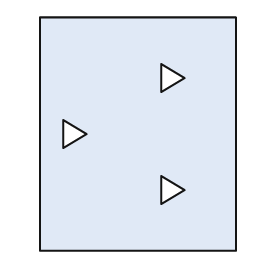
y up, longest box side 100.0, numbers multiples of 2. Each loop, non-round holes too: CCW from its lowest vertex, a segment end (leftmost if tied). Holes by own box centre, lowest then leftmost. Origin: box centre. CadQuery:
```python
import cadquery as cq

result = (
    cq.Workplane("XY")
    .moveTo(-42.0, -50.0)
    .lineTo(42.0, -50.0)
    .lineTo(42.0, 50.0)
    .lineTo(-42.0, 50.0)
    .close()
    .moveTo(10.0, -30.0)
    .lineTo(20.0, -24.0)
    .lineTo(10.0, -18.0)
    .close()
    .moveTo(-32.0, -6.0)
    .lineTo(-22.0, 0.0)
    .lineTo(-32.0, 6.0)
    .close()
    .moveTo(10.0, 18.0)
    .lineTo(20.0, 24.0)
    .lineTo(10.0, 30.0)
    .close()
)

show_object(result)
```